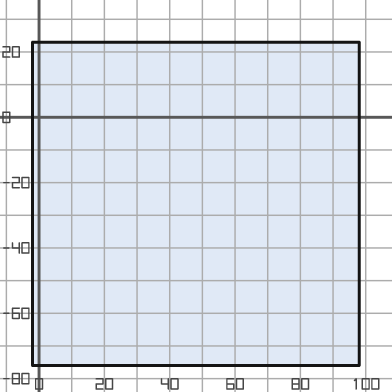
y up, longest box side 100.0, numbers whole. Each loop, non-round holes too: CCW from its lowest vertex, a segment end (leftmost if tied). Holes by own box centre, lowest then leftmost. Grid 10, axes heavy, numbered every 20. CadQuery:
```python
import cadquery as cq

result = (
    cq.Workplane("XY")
    .moveTo(-2.0, -76.0)
    .lineTo(98.0, -76.0)
    .lineTo(98.0, 23.0)
    .lineTo(-2.0, 23.0)
    .close()
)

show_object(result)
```